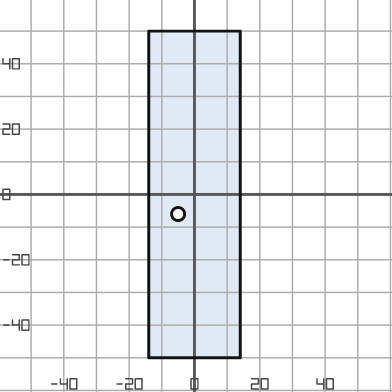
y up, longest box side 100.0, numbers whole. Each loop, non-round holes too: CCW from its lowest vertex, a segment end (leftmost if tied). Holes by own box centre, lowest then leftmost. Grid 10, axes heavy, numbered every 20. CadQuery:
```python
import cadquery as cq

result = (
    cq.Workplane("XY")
    .moveTo(-14.0, -50.0)
    .lineTo(14.0, -50.0)
    .lineTo(14.0, 50.0)
    .lineTo(-14.0, 50.0)
    .close()
    .moveTo(-5.0, -6.0)
    .circle(2.0)
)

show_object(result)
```